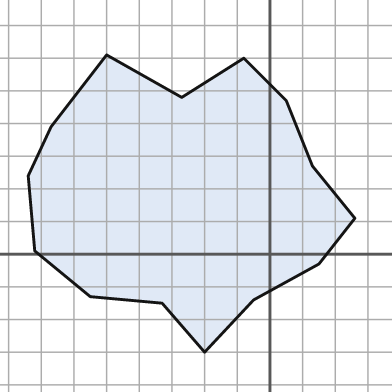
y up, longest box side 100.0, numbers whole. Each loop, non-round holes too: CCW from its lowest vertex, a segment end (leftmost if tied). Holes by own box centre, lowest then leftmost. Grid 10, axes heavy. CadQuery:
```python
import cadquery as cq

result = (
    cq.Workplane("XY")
    .moveTo(-20.0, -30.0)
    .lineTo(-5.0, -14.0)
    .lineTo(15.0, -3.0)
    .lineTo(26.0, 11.0)
    .lineTo(13.0, 27.0)
    .lineTo(5.0, 47.0)
    .lineTo(-8.0, 60.0)
    .lineTo(-27.0, 48.0)
    .lineTo(-50.0, 61.0)
    .lineTo(-67.0, 39.0)
    .lineTo(-74.0, 24.0)
    .lineTo(-72.0, 1.0)
    .lineTo(-55.0, -13.0)
    .lineTo(-33.0, -15.0)
    .close()
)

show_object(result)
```